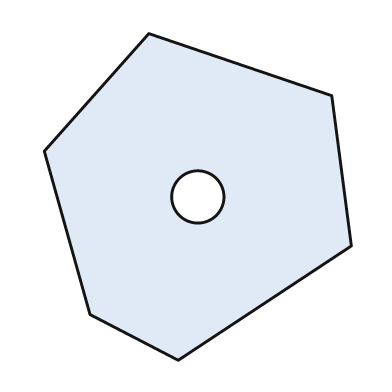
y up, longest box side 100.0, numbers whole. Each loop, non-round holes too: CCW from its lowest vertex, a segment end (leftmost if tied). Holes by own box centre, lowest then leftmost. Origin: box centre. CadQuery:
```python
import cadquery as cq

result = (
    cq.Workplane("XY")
    .moveTo(-6.0, -50.0)
    .lineTo(47.0, -15.0)
    .lineTo(41.0, 31.0)
    .lineTo(-15.0, 50.0)
    .lineTo(-47.0, 14.0)
    .lineTo(-33.0, -36.0)
    .close()
    .moveTo(0.0, 0.0)
    .circle(8.0)
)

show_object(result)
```